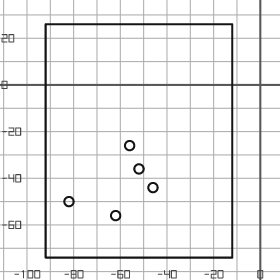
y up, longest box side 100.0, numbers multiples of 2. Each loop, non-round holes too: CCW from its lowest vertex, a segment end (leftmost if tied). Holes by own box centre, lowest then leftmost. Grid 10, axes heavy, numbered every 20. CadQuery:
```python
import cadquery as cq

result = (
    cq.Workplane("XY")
    .moveTo(-92.0, -74.0)
    .lineTo(-12.0, -74.0)
    .lineTo(-12.0, 26.0)
    .lineTo(-92.0, 26.0)
    .close()
    .moveTo(-62.0, -56.0)
    .circle(2.0)
    .moveTo(-82.0, -50.0)
    .circle(2.0)
    .moveTo(-46.0, -44.0)
    .circle(2.0)
    .moveTo(-52.0, -36.0)
    .circle(2.0)
    .moveTo(-56.0, -26.0)
    .circle(2.0)
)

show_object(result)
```